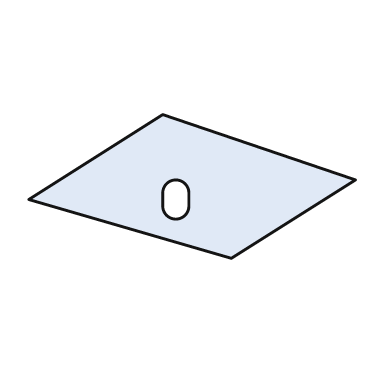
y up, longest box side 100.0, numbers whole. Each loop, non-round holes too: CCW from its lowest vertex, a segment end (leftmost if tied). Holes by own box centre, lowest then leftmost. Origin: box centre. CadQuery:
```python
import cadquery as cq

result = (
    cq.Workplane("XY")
    .moveTo(12.0, -22.0)
    .lineTo(50.0, 2.0)
    .lineTo(-9.0, 22.0)
    .lineTo(-50.0, -4.0)
    .close()
    .moveTo(-9.0, -6.0)
    .threePointArc((-5.0, -10.0), (-1.0, -6.0))
    .lineTo(-1.0, -2.0)
    .threePointArc((-5.0, 2.0), (-9.0, -2.0))
    .close()
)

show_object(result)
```